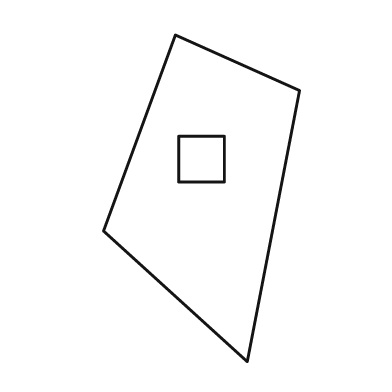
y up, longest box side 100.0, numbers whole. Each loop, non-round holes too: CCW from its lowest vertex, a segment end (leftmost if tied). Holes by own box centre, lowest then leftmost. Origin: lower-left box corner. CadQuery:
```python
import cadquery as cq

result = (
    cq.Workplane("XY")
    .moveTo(44.0, 0.0)
    .lineTo(60.0, 83.0)
    .lineTo(22.0, 100.0)
    .lineTo(0.0, 40.0)
    .close()
    .moveTo(23.0, 55.0)
    .lineTo(37.0, 55.0)
    .lineTo(37.0, 69.0)
    .lineTo(23.0, 69.0)
    .close()
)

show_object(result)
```